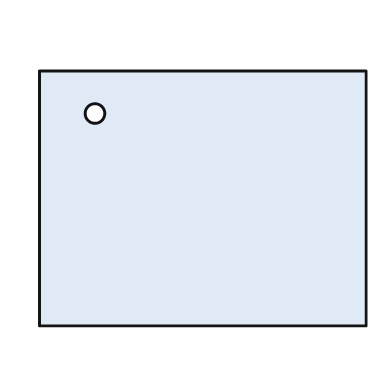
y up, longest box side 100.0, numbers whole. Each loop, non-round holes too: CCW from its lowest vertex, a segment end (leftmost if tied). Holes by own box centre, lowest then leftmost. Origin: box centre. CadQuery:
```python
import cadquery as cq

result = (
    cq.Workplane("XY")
    .moveTo(-50.0, -39.0)
    .lineTo(50.0, -39.0)
    .lineTo(50.0, 39.0)
    .lineTo(-50.0, 39.0)
    .close()
    .moveTo(-33.0, 26.0)
    .circle(3.0)
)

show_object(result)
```